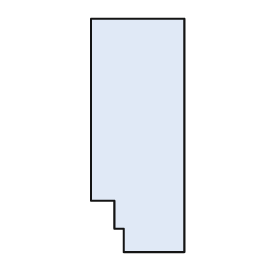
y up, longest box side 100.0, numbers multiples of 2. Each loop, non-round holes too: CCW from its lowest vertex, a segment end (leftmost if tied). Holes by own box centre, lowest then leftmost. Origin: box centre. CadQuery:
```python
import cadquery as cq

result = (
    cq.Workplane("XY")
    .moveTo(-6.0, -50.0)
    .lineTo(20.0, -50.0)
    .lineTo(20.0, 50.0)
    .lineTo(-20.0, 50.0)
    .lineTo(-20.0, -28.0)
    .lineTo(-10.0, -28.0)
    .lineTo(-10.0, -40.0)
    .lineTo(-6.0, -40.0)
    .close()
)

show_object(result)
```